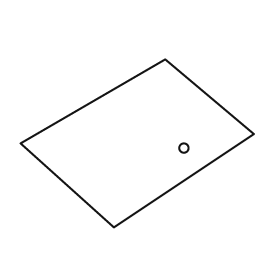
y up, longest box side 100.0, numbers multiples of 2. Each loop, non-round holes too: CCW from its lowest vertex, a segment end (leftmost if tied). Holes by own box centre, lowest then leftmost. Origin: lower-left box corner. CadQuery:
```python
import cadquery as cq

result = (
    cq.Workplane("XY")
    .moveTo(40.0, 0.0)
    .lineTo(100.0, 40.0)
    .lineTo(62.0, 72.0)
    .lineTo(0.0, 36.0)
    .close()
    .moveTo(70.0, 34.0)
    .circle(2.0)
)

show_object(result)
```